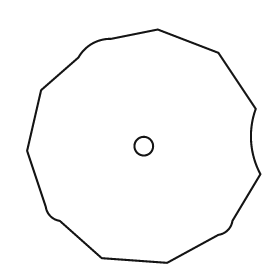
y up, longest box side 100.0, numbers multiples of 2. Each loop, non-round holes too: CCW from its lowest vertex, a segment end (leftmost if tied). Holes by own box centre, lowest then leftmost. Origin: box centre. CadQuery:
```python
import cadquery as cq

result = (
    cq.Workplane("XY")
    .moveTo(10.0, -50.0)
    .lineTo(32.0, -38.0)
    .threePointArc((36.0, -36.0), (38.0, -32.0))
    .lineTo(50.0, -12.0)
    .threePointArc((46.0, 2.0), (48.0, 16.0))
    .lineTo(32.0, 40.0)
    .lineTo(6.0, 50.0)
    .lineTo(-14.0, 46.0)
    .threePointArc((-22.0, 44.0), (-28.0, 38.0))
    .lineTo(-44.0, 24.0)
    .lineTo(-50.0, -2.0)
    .lineTo(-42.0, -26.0)
    .threePointArc((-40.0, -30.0), (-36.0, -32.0))
    .lineTo(-18.0, -48.0)
    .close()
    .moveTo(0.0, 0.0)
    .circle(4.0)
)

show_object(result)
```